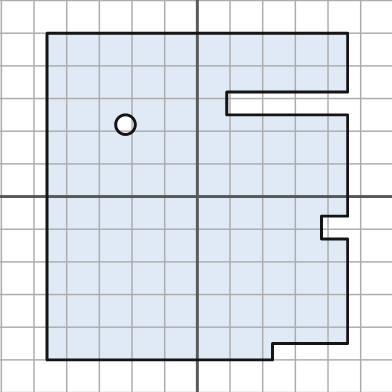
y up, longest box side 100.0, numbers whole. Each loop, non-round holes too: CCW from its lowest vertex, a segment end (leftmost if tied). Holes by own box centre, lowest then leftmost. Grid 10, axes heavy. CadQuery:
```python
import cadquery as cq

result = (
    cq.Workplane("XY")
    .moveTo(-46.0, -50.0)
    .lineTo(23.0, -50.0)
    .lineTo(23.0, -45.0)
    .lineTo(46.0, -45.0)
    .lineTo(46.0, -13.0)
    .lineTo(38.0, -13.0)
    .lineTo(38.0, -6.0)
    .lineTo(46.0, -6.0)
    .lineTo(46.0, 25.0)
    .lineTo(9.0, 25.0)
    .lineTo(9.0, 32.0)
    .lineTo(46.0, 32.0)
    .lineTo(46.0, 50.0)
    .lineTo(-46.0, 50.0)
    .close()
    .moveTo(-22.0, 22.0)
    .circle(3.0)
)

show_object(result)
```